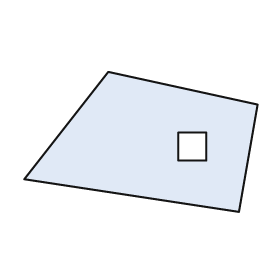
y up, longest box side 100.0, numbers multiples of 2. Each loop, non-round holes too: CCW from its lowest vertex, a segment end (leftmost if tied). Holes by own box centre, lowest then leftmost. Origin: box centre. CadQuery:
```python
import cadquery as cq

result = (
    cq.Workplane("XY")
    .moveTo(42.0, -30.0)
    .lineTo(50.0, 16.0)
    .lineTo(-14.0, 30.0)
    .lineTo(-50.0, -16.0)
    .close()
    .moveTo(16.0, -8.0)
    .lineTo(28.0, -8.0)
    .lineTo(28.0, 4.0)
    .lineTo(16.0, 4.0)
    .close()
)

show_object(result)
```